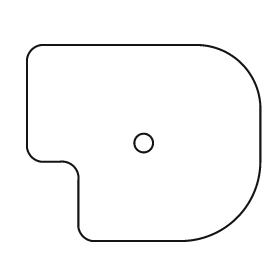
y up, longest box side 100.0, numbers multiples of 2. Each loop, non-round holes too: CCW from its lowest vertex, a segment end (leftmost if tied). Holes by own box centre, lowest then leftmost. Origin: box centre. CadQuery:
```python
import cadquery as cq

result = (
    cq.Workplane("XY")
    .moveTo(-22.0, -42.0)
    .lineTo(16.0, -42.0)
    .threePointArc((40.0, -32.0), (50.0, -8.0))
    .lineTo(50.0, 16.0)
    .threePointArc((42.0, 34.0), (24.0, 42.0))
    .lineTo(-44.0, 42.0)
    .threePointArc((-48.0, 40.0), (-50.0, 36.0))
    .lineTo(-50.0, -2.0)
    .threePointArc((-48.0, -6.0), (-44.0, -8.0))
    .lineTo(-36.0, -8.0)
    .threePointArc((-30.0, -10.0), (-28.0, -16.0))
    .lineTo(-28.0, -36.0)
    .threePointArc((-26.0, -40.0), (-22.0, -42.0))
    .close()
    .moveTo(0.0, 0.0)
    .circle(4.0)
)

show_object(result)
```